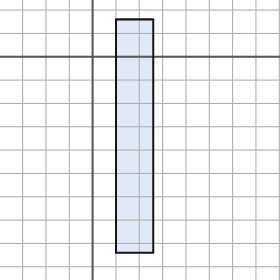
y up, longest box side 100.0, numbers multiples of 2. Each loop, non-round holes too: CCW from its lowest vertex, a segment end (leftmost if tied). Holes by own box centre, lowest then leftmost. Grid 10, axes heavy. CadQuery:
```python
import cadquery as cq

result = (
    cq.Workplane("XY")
    .moveTo(10.0, -84.0)
    .lineTo(26.0, -84.0)
    .lineTo(26.0, 16.0)
    .lineTo(10.0, 16.0)
    .close()
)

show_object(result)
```